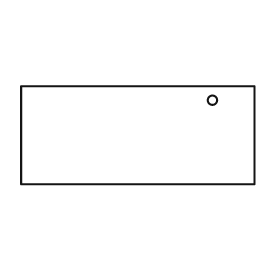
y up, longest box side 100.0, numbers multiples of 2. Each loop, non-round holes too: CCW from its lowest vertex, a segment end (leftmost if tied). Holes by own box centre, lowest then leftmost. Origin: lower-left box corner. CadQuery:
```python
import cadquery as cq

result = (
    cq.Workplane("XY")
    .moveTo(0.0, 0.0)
    .lineTo(100.0, 0.0)
    .lineTo(100.0, 42.0)
    .lineTo(0.0, 42.0)
    .close()
    .moveTo(82.0, 36.0)
    .circle(2.0)
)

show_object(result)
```